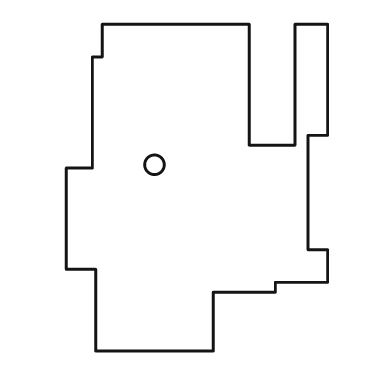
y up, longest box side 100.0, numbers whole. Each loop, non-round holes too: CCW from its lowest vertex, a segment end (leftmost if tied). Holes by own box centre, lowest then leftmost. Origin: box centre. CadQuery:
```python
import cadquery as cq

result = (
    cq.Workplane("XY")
    .moveTo(-31.0, -50.0)
    .lineTo(5.0, -50.0)
    .lineTo(5.0, -32.0)
    .lineTo(24.0, -32.0)
    .lineTo(24.0, -29.0)
    .lineTo(40.0, -29.0)
    .lineTo(40.0, -19.0)
    .lineTo(34.0, -19.0)
    .lineTo(34.0, 16.0)
    .lineTo(40.0, 16.0)
    .lineTo(40.0, 50.0)
    .lineTo(30.0, 50.0)
    .lineTo(30.0, 13.0)
    .lineTo(16.0, 13.0)
    .lineTo(16.0, 50.0)
    .lineTo(-29.0, 50.0)
    .lineTo(-29.0, 40.0)
    .lineTo(-32.0, 40.0)
    .lineTo(-32.0, 6.0)
    .lineTo(-40.0, 6.0)
    .lineTo(-40.0, -25.0)
    .lineTo(-31.0, -25.0)
    .close()
    .moveTo(-13.0, 7.0)
    .circle(3.0)
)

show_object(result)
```